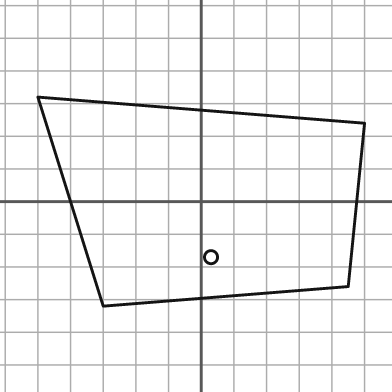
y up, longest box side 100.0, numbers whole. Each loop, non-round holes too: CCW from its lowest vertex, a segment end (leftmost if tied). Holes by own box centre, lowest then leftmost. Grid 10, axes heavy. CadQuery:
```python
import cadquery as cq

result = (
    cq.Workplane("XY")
    .moveTo(-30.0, -32.0)
    .lineTo(45.0, -26.0)
    .lineTo(50.0, 24.0)
    .lineTo(-50.0, 32.0)
    .close()
    .moveTo(3.0, -17.0)
    .circle(2.0)
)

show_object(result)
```